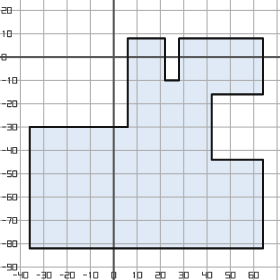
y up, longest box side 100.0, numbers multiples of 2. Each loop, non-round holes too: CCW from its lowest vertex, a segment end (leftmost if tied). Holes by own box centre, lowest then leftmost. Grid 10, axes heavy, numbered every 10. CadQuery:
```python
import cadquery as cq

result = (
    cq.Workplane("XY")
    .moveTo(-36.0, -82.0)
    .lineTo(64.0, -82.0)
    .lineTo(64.0, -44.0)
    .lineTo(42.0, -44.0)
    .lineTo(42.0, -16.0)
    .lineTo(64.0, -16.0)
    .lineTo(64.0, 8.0)
    .lineTo(28.0, 8.0)
    .lineTo(28.0, -10.0)
    .lineTo(22.0, -10.0)
    .lineTo(22.0, 8.0)
    .lineTo(6.0, 8.0)
    .lineTo(6.0, -30.0)
    .lineTo(-36.0, -30.0)
    .close()
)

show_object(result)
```